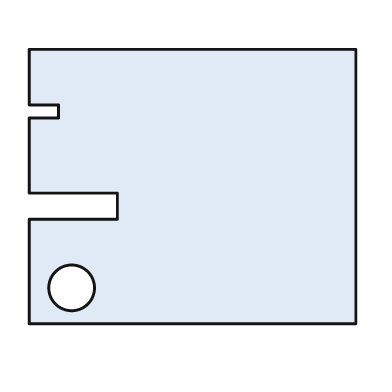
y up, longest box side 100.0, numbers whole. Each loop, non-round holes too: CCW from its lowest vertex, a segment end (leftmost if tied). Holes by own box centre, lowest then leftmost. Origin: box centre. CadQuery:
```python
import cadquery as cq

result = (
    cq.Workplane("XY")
    .moveTo(-50.0, -42.0)
    .lineTo(50.0, -42.0)
    .lineTo(50.0, 42.0)
    .lineTo(-50.0, 42.0)
    .lineTo(-50.0, 25.0)
    .lineTo(-41.0, 25.0)
    .lineTo(-41.0, 21.0)
    .lineTo(-50.0, 21.0)
    .lineTo(-50.0, -2.0)
    .lineTo(-23.0, -2.0)
    .lineTo(-23.0, -10.0)
    .lineTo(-50.0, -10.0)
    .close()
    .moveTo(-37.0, -31.0)
    .circle(7.0)
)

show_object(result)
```